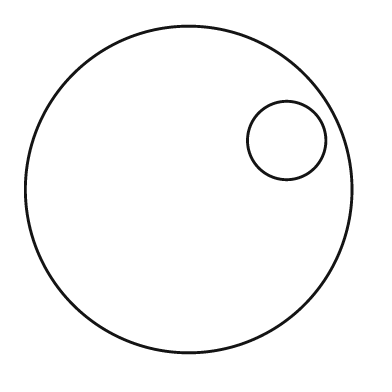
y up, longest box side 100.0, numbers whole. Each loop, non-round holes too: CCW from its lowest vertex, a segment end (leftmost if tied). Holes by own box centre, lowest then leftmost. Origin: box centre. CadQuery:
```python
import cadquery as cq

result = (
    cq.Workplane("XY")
    .moveTo(0.0, 0.0)
    .circle(50.0)
    .moveTo(30.0, 15.0)
    .circle(12.0)
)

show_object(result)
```